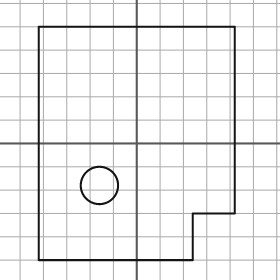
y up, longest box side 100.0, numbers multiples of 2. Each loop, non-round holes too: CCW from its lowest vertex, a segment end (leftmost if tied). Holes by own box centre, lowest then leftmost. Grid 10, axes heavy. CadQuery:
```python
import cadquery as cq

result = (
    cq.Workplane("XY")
    .moveTo(-42.0, -50.0)
    .lineTo(24.0, -50.0)
    .lineTo(24.0, -30.0)
    .lineTo(42.0, -30.0)
    .lineTo(42.0, 50.0)
    .lineTo(-42.0, 50.0)
    .close()
    .moveTo(-16.0, -18.0)
    .circle(8.0)
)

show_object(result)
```